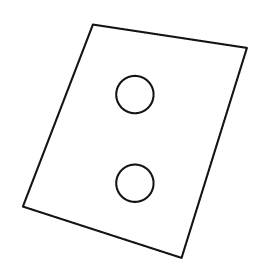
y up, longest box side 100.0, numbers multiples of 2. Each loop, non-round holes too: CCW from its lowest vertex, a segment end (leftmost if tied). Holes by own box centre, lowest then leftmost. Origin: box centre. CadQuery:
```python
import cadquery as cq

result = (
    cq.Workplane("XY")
    .moveTo(20.0, -50.0)
    .lineTo(48.0, 40.0)
    .lineTo(-18.0, 50.0)
    .lineTo(-48.0, -28.0)
    .close()
    .moveTo(0.0, -18.0)
    .circle(8.0)
    .moveTo(0.0, 20.0)
    .circle(8.0)
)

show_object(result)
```